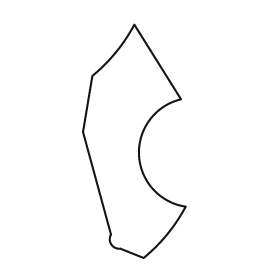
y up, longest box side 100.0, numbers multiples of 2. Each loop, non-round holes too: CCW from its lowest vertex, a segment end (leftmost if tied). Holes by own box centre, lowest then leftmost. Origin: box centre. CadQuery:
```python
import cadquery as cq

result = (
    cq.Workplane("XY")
    .moveTo(4.0, -50.0)
    .threePointArc((14.0, -40.0), (22.0, -28.0))
    .threePointArc((2.0, -6.0), (20.0, 18.0))
    .lineTo(0.0, 50.0)
    .threePointArc((-8.0, 38.0), (-18.0, 28.0))
    .lineTo(-22.0, 4.0)
    .lineTo(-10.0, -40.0)
    .threePointArc((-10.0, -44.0), (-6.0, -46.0))
    .close()
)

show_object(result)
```